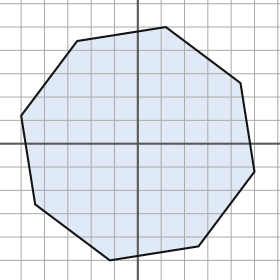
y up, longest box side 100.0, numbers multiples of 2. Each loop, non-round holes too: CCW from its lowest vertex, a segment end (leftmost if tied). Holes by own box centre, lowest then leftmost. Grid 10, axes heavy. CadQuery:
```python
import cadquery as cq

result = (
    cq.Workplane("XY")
    .moveTo(-12.0, -50.0)
    .lineTo(26.0, -44.0)
    .lineTo(50.0, -12.0)
    .lineTo(44.0, 26.0)
    .lineTo(12.0, 50.0)
    .lineTo(-26.0, 44.0)
    .lineTo(-50.0, 12.0)
    .lineTo(-44.0, -26.0)
    .close()
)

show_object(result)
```